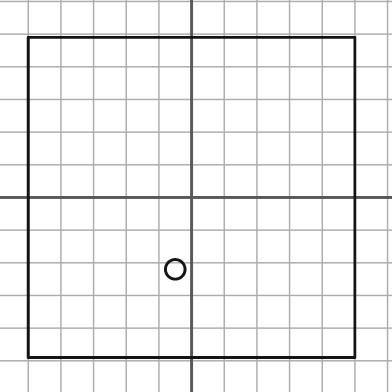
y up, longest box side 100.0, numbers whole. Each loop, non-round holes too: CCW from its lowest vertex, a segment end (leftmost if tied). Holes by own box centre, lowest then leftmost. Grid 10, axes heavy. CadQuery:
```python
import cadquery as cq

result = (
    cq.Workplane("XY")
    .moveTo(-50.0, -49.0)
    .lineTo(50.0, -49.0)
    .lineTo(50.0, 49.0)
    .lineTo(-50.0, 49.0)
    .close()
    .moveTo(-5.0, -22.0)
    .circle(3.0)
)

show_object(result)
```